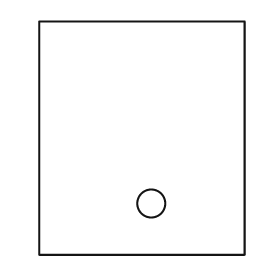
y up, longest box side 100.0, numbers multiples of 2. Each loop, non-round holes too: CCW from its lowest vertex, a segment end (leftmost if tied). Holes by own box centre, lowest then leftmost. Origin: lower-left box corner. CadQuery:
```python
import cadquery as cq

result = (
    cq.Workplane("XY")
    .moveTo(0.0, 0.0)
    .lineTo(88.0, 0.0)
    .lineTo(88.0, 100.0)
    .lineTo(0.0, 100.0)
    .close()
    .moveTo(48.0, 22.0)
    .circle(6.0)
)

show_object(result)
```